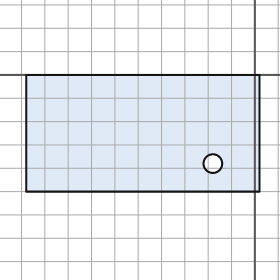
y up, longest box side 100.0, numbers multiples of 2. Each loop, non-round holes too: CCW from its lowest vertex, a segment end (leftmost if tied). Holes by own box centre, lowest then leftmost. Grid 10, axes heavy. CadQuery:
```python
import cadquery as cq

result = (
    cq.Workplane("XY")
    .moveTo(-98.0, -50.0)
    .lineTo(2.0, -50.0)
    .lineTo(2.0, 0.0)
    .lineTo(-98.0, 0.0)
    .close()
    .moveTo(-18.0, -38.0)
    .circle(4.0)
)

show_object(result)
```